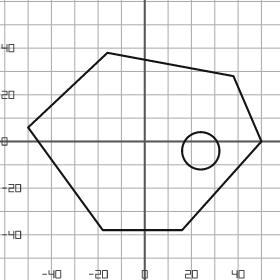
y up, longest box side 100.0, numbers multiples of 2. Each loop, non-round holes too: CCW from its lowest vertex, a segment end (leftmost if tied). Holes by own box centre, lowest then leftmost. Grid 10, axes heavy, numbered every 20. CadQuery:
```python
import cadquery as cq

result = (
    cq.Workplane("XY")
    .moveTo(-18.0, -38.0)
    .lineTo(16.0, -38.0)
    .lineTo(50.0, 0.0)
    .lineTo(38.0, 28.0)
    .lineTo(-16.0, 38.0)
    .lineTo(-50.0, 6.0)
    .close()
    .moveTo(24.0, -4.0)
    .circle(8.0)
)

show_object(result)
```